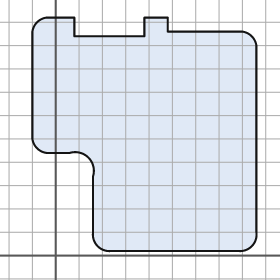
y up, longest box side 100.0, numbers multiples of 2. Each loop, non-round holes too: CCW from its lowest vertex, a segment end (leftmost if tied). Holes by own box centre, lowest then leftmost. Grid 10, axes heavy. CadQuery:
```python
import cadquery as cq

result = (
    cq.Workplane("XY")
    .moveTo(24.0, 2.0)
    .lineTo(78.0, 2.0)
    .threePointArc((84.0, 4.0), (86.0, 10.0))
    .lineTo(86.0, 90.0)
    .threePointArc((84.0, 94.0), (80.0, 96.0))
    .lineTo(48.0, 96.0)
    .lineTo(48.0, 102.0)
    .lineTo(38.0, 102.0)
    .lineTo(38.0, 94.0)
    .lineTo(8.0, 94.0)
    .lineTo(8.0, 102.0)
    .lineTo(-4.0, 102.0)
    .threePointArc((-8.0, 100.0), (-10.0, 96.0))
    .lineTo(-10.0, 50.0)
    .threePointArc((-8.0, 46.0), (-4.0, 44.0))
    .lineTo(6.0, 44.0)
    .threePointArc((14.0, 42.0), (16.0, 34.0))
    .lineTo(16.0, 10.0)
    .threePointArc((18.0, 4.0), (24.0, 2.0))
    .close()
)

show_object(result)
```